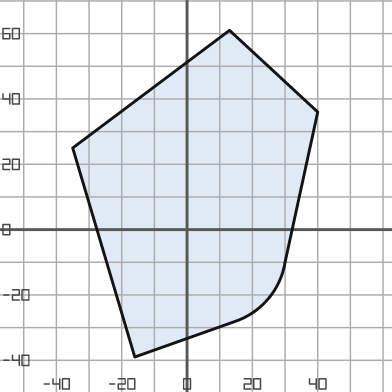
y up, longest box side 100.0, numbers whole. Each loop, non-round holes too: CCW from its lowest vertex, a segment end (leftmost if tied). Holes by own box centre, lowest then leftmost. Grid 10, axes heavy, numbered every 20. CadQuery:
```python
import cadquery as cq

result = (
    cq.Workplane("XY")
    .moveTo(-16.0, -39.0)
    .lineTo(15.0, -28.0)
    .threePointArc((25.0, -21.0), (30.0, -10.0))
    .lineTo(40.0, 36.0)
    .lineTo(13.0, 61.0)
    .lineTo(-35.0, 25.0)
    .close()
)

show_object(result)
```